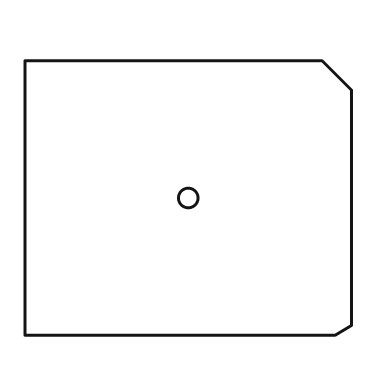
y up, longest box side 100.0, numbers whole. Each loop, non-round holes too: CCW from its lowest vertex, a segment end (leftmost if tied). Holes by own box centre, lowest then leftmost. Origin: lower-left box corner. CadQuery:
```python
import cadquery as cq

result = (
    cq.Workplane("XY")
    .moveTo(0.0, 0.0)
    .lineTo(95.0, 0.0)
    .lineTo(100.0, 3.0)
    .lineTo(100.0, 75.0)
    .lineTo(91.0, 84.0)
    .lineTo(0.0, 84.0)
    .close()
    .moveTo(50.0, 42.0)
    .circle(3.0)
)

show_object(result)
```